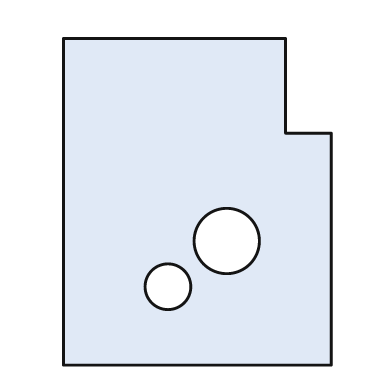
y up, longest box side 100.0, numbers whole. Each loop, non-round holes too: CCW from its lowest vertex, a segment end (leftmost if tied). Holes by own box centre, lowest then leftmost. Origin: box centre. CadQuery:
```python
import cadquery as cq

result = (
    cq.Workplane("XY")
    .moveTo(-41.0, -50.0)
    .lineTo(41.0, -50.0)
    .lineTo(41.0, 21.0)
    .lineTo(27.0, 21.0)
    .lineTo(27.0, 50.0)
    .lineTo(-41.0, 50.0)
    .close()
    .moveTo(-9.0, -26.0)
    .circle(7.0)
    .moveTo(9.0, -12.0)
    .circle(10.0)
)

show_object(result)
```